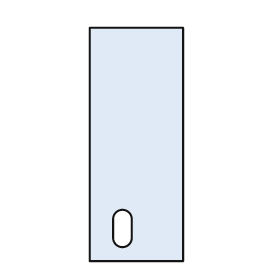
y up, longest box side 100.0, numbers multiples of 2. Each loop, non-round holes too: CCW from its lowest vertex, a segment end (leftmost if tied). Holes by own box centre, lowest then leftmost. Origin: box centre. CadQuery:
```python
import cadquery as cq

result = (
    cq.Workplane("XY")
    .moveTo(-20.0, -50.0)
    .lineTo(20.0, -50.0)
    .lineTo(20.0, 50.0)
    .lineTo(-20.0, 50.0)
    .close()
    .moveTo(-10.0, -40.0)
    .threePointArc((-6.0, -44.0), (-2.0, -40.0))
    .lineTo(-2.0, -32.0)
    .threePointArc((-6.0, -28.0), (-10.0, -32.0))
    .close()
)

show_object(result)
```